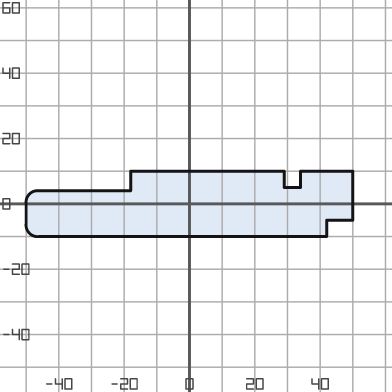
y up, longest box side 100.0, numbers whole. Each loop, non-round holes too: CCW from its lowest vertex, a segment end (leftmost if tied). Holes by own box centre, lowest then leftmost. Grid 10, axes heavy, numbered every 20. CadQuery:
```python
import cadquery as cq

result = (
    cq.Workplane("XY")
    .moveTo(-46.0, -10.0)
    .lineTo(42.0, -10.0)
    .lineTo(42.0, -5.0)
    .lineTo(50.0, -5.0)
    .lineTo(50.0, 10.0)
    .lineTo(34.0, 10.0)
    .lineTo(34.0, 5.0)
    .lineTo(29.0, 5.0)
    .lineTo(29.0, 10.0)
    .lineTo(-18.0, 10.0)
    .lineTo(-18.0, 4.0)
    .lineTo(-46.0, 4.0)
    .threePointArc((-49.0, 3.0), (-50.0, 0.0))
    .lineTo(-50.0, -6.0)
    .threePointArc((-49.0, -9.0), (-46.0, -10.0))
    .close()
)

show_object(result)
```